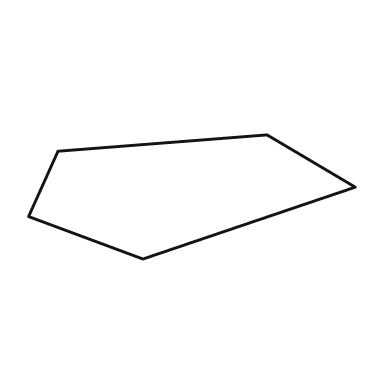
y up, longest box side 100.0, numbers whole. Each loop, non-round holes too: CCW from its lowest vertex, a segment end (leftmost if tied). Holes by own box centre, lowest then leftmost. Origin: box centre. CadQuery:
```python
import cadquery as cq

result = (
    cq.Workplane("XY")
    .moveTo(-15.0, -19.0)
    .lineTo(50.0, 3.0)
    .lineTo(23.0, 19.0)
    .lineTo(-41.0, 14.0)
    .lineTo(-50.0, -6.0)
    .close()
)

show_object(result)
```